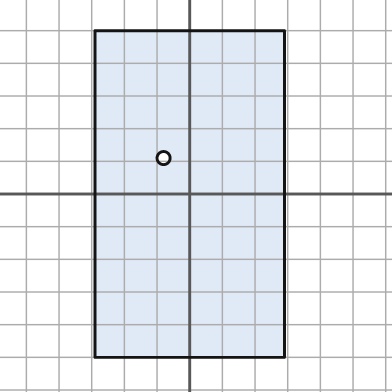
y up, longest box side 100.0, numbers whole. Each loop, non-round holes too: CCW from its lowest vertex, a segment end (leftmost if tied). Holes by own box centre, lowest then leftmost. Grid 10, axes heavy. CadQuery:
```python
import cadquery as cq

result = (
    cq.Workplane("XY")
    .moveTo(-29.0, -50.0)
    .lineTo(29.0, -50.0)
    .lineTo(29.0, 50.0)
    .lineTo(-29.0, 50.0)
    .close()
    .moveTo(-8.0, 11.0)
    .circle(2.0)
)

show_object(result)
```